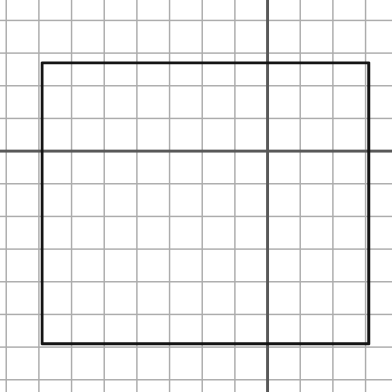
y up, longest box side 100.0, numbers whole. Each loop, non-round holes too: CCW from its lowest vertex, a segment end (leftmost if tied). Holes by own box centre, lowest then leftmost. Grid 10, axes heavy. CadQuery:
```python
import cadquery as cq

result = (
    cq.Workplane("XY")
    .moveTo(-69.0, -59.0)
    .lineTo(31.0, -59.0)
    .lineTo(31.0, 27.0)
    .lineTo(-69.0, 27.0)
    .close()
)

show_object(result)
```